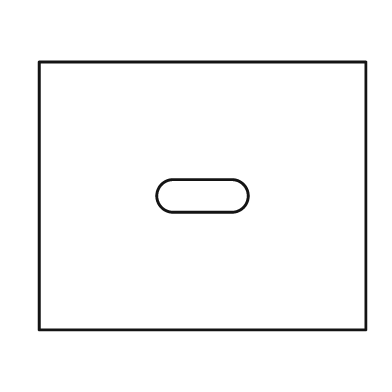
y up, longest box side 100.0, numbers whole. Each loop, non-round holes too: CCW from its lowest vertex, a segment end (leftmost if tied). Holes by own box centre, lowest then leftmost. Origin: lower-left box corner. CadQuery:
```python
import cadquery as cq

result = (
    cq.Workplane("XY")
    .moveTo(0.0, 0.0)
    .lineTo(100.0, 0.0)
    .lineTo(100.0, 82.0)
    .lineTo(0.0, 82.0)
    .close()
    .moveTo(41.0, 36.0)
    .lineTo(59.0, 36.0)
    .threePointArc((64.0, 41.0), (59.0, 46.0))
    .lineTo(41.0, 46.0)
    .threePointArc((36.0, 41.0), (41.0, 36.0))
    .close()
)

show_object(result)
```